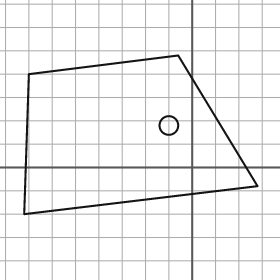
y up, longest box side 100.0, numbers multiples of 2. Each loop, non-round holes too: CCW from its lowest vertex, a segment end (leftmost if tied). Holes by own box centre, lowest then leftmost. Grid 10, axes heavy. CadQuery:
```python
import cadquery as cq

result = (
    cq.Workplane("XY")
    .moveTo(-72.0, -20.0)
    .lineTo(28.0, -8.0)
    .lineTo(-6.0, 48.0)
    .lineTo(-70.0, 40.0)
    .close()
    .moveTo(-10.0, 18.0)
    .circle(4.0)
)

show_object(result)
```